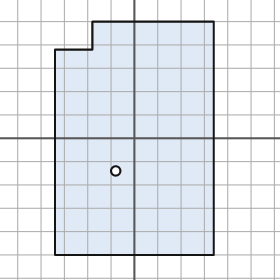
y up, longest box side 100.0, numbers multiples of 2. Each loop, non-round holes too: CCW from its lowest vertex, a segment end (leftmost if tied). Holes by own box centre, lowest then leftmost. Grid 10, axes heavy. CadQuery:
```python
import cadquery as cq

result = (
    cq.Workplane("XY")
    .moveTo(-34.0, -50.0)
    .lineTo(34.0, -50.0)
    .lineTo(34.0, 50.0)
    .lineTo(-18.0, 50.0)
    .lineTo(-18.0, 38.0)
    .lineTo(-34.0, 38.0)
    .close()
    .moveTo(-8.0, -14.0)
    .circle(2.0)
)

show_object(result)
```